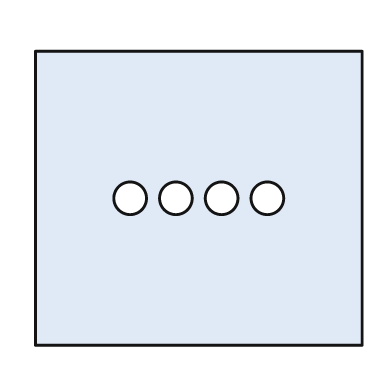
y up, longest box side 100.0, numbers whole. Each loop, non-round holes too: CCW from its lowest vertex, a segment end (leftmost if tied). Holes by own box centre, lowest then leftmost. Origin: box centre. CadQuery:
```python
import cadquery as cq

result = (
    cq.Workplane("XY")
    .moveTo(-50.0, -45.0)
    .lineTo(50.0, -45.0)
    .lineTo(50.0, 45.0)
    .lineTo(-50.0, 45.0)
    .close()
    .moveTo(-21.0, 0.0)
    .circle(5.0)
    .moveTo(-7.0, 0.0)
    .circle(5.0)
    .moveTo(7.0, 0.0)
    .circle(5.0)
    .moveTo(21.0, 0.0)
    .circle(5.0)
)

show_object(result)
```